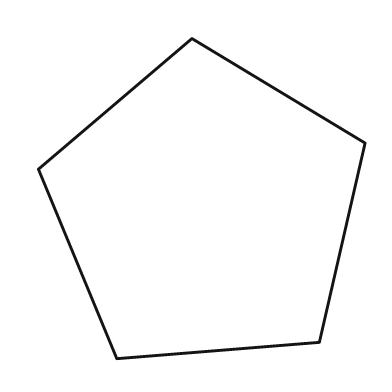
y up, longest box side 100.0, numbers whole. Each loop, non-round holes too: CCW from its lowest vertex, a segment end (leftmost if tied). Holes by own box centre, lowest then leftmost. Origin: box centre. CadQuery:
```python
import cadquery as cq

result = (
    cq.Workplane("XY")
    .moveTo(-26.0, -49.0)
    .lineTo(36.0, -44.0)
    .lineTo(50.0, 17.0)
    .lineTo(-3.0, 49.0)
    .lineTo(-50.0, 9.0)
    .close()
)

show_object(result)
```